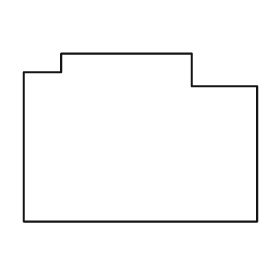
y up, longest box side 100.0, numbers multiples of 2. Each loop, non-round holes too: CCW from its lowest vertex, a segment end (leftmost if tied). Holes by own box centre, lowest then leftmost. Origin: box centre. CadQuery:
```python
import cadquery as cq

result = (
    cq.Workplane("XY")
    .moveTo(-50.0, -36.0)
    .lineTo(50.0, -36.0)
    .lineTo(50.0, 22.0)
    .lineTo(22.0, 22.0)
    .lineTo(22.0, 36.0)
    .lineTo(-34.0, 36.0)
    .lineTo(-34.0, 28.0)
    .lineTo(-50.0, 28.0)
    .close()
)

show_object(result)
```